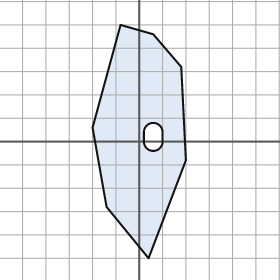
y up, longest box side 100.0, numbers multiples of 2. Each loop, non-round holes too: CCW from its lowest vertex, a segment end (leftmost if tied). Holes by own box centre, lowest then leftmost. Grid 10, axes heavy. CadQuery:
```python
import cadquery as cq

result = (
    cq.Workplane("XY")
    .moveTo(4.0, -50.0)
    .lineTo(20.0, -8.0)
    .lineTo(18.0, 32.0)
    .lineTo(6.0, 46.0)
    .lineTo(-8.0, 50.0)
    .lineTo(-20.0, 6.0)
    .lineTo(-14.0, -28.0)
    .close()
    .moveTo(2.0, 0.0)
    .threePointArc((6.0, -4.0), (10.0, 0.0))
    .lineTo(10.0, 4.0)
    .threePointArc((6.0, 8.0), (2.0, 4.0))
    .close()
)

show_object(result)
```